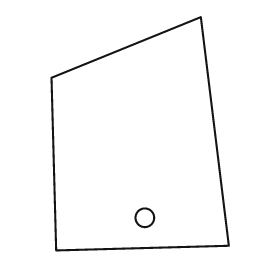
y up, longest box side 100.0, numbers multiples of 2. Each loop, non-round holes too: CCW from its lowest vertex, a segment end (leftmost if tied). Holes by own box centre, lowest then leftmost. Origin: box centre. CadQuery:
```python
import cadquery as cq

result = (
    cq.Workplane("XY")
    .moveTo(-36.0, -50.0)
    .lineTo(38.0, -48.0)
    .lineTo(26.0, 50.0)
    .lineTo(-38.0, 24.0)
    .close()
    .moveTo(2.0, -36.0)
    .circle(4.0)
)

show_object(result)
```